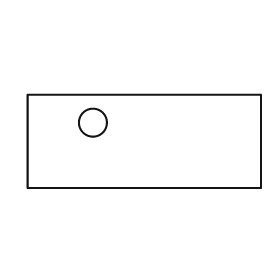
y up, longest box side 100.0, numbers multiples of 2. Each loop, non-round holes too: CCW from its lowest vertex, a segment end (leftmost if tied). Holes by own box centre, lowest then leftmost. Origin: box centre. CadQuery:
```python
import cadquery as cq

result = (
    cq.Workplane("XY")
    .moveTo(-50.0, -20.0)
    .lineTo(50.0, -20.0)
    .lineTo(50.0, 20.0)
    .lineTo(-50.0, 20.0)
    .close()
    .moveTo(-22.0, 8.0)
    .circle(6.0)
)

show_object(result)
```